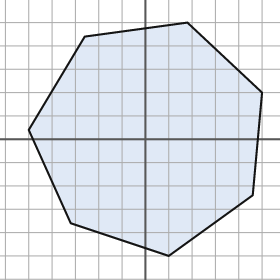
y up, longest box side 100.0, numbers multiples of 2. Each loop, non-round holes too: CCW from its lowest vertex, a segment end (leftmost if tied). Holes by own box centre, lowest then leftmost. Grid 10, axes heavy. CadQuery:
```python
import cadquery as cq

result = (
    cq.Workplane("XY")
    .moveTo(10.0, -50.0)
    .lineTo(46.0, -24.0)
    .lineTo(50.0, 20.0)
    .lineTo(18.0, 50.0)
    .lineTo(-26.0, 44.0)
    .lineTo(-50.0, 4.0)
    .lineTo(-32.0, -36.0)
    .close()
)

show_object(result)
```